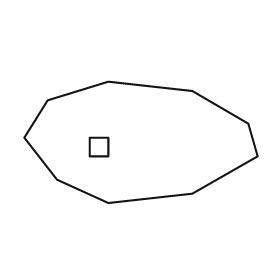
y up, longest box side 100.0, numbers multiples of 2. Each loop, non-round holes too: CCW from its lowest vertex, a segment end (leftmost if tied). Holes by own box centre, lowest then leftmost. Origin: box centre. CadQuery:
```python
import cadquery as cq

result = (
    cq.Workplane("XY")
    .moveTo(-14.0, -26.0)
    .lineTo(22.0, -22.0)
    .lineTo(50.0, -6.0)
    .lineTo(46.0, 8.0)
    .lineTo(22.0, 22.0)
    .lineTo(-14.0, 26.0)
    .lineTo(-40.0, 18.0)
    .lineTo(-50.0, 2.0)
    .lineTo(-36.0, -16.0)
    .close()
    .moveTo(-22.0, -6.0)
    .lineTo(-14.0, -6.0)
    .lineTo(-14.0, 2.0)
    .lineTo(-22.0, 2.0)
    .close()
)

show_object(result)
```